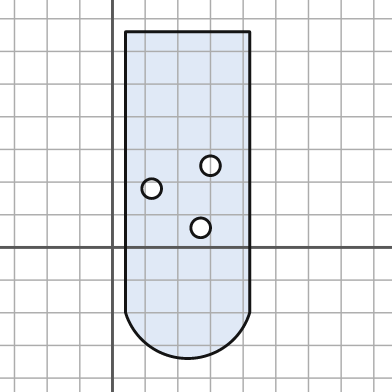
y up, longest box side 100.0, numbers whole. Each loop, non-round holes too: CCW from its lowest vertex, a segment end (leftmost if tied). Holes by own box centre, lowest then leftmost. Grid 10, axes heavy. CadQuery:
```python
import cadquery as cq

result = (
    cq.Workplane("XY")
    .moveTo(4.0, -20.0)
    .threePointArc((23.0, -34.0), (42.0, -20.0))
    .lineTo(42.0, 66.0)
    .lineTo(4.0, 66.0)
    .close()
    .moveTo(27.0, 6.0)
    .circle(3.0)
    .moveTo(12.0, 18.0)
    .circle(3.0)
    .moveTo(30.0, 25.0)
    .circle(3.0)
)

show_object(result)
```